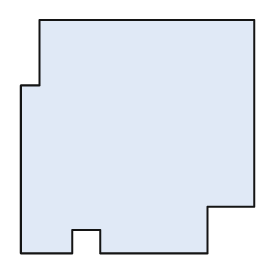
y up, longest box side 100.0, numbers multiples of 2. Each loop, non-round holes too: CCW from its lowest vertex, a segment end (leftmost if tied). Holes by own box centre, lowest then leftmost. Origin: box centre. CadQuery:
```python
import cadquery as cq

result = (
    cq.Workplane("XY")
    .moveTo(-50.0, -50.0)
    .lineTo(-28.0, -50.0)
    .lineTo(-28.0, -40.0)
    .lineTo(-16.0, -40.0)
    .lineTo(-16.0, -50.0)
    .lineTo(30.0, -50.0)
    .lineTo(30.0, -30.0)
    .lineTo(50.0, -30.0)
    .lineTo(50.0, 50.0)
    .lineTo(-42.0, 50.0)
    .lineTo(-42.0, 22.0)
    .lineTo(-50.0, 22.0)
    .close()
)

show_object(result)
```